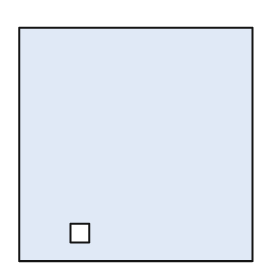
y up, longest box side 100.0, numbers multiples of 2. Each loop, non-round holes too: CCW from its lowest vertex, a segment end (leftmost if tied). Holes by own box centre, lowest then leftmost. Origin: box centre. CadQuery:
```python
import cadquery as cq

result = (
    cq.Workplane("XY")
    .moveTo(-50.0, -50.0)
    .lineTo(50.0, -50.0)
    .lineTo(50.0, 50.0)
    .lineTo(-50.0, 50.0)
    .close()
    .moveTo(-28.0, -42.0)
    .lineTo(-20.0, -42.0)
    .lineTo(-20.0, -34.0)
    .lineTo(-28.0, -34.0)
    .close()
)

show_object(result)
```